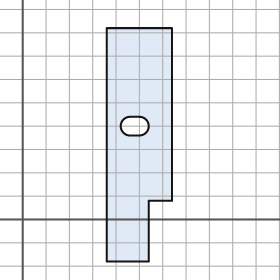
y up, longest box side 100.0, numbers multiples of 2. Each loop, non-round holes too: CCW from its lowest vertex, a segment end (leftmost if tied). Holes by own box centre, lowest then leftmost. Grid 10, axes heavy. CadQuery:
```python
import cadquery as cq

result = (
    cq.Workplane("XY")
    .moveTo(36.0, -18.0)
    .lineTo(54.0, -18.0)
    .lineTo(54.0, 8.0)
    .lineTo(64.0, 8.0)
    .lineTo(64.0, 82.0)
    .lineTo(36.0, 82.0)
    .close()
    .moveTo(46.0, 36.0)
    .lineTo(50.0, 36.0)
    .threePointArc((54.0, 40.0), (50.0, 44.0))
    .lineTo(46.0, 44.0)
    .threePointArc((42.0, 40.0), (46.0, 36.0))
    .close()
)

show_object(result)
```